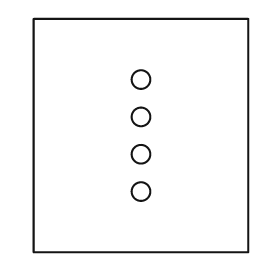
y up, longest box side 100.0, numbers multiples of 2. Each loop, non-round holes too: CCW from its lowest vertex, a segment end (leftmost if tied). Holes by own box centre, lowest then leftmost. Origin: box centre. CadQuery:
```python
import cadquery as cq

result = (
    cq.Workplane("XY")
    .moveTo(-46.0, -50.0)
    .lineTo(46.0, -50.0)
    .lineTo(46.0, 50.0)
    .lineTo(-46.0, 50.0)
    .close()
    .moveTo(0.0, -24.0)
    .circle(4.0)
    .moveTo(0.0, -8.0)
    .circle(4.0)
    .moveTo(0.0, 8.0)
    .circle(4.0)
    .moveTo(0.0, 24.0)
    .circle(4.0)
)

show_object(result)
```